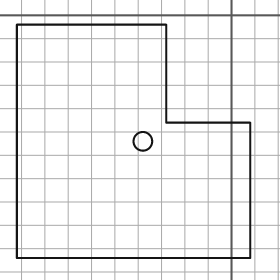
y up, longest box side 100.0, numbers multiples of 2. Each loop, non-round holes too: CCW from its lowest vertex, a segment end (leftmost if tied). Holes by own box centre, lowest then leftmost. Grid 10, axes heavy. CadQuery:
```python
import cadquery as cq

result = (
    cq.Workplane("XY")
    .moveTo(-92.0, -104.0)
    .lineTo(8.0, -104.0)
    .lineTo(8.0, -46.0)
    .lineTo(-28.0, -46.0)
    .lineTo(-28.0, -4.0)
    .lineTo(-92.0, -4.0)
    .close()
    .moveTo(-38.0, -54.0)
    .circle(4.0)
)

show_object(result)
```